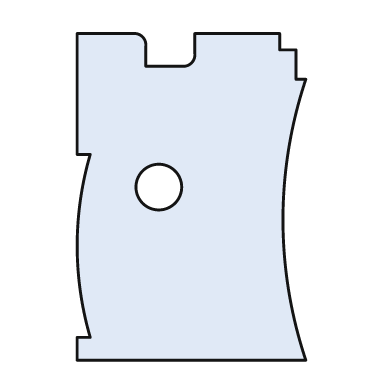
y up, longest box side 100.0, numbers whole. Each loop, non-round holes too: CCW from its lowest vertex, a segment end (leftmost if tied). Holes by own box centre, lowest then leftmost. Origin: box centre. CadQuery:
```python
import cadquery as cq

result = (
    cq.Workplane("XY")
    .moveTo(-35.0, -50.0)
    .lineTo(35.0, -50.0)
    .threePointArc((28.0, -7.0), (35.0, 36.0))
    .lineTo(32.0, 36.0)
    .lineTo(32.0, 45.0)
    .lineTo(27.0, 45.0)
    .lineTo(27.0, 50.0)
    .lineTo(1.0, 50.0)
    .lineTo(1.0, 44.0)
    .threePointArc((0.0, 41.0), (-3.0, 40.0))
    .lineTo(-14.0, 40.0)
    .lineTo(-14.0, 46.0)
    .threePointArc((-15.0, 49.0), (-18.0, 50.0))
    .lineTo(-35.0, 50.0)
    .lineTo(-35.0, 13.0)
    .lineTo(-31.0, 13.0)
    .threePointArc((-35.0, -15.0), (-31.0, -43.0))
    .lineTo(-35.0, -43.0)
    .close()
    .moveTo(-10.0, 3.0)
    .circle(7.0)
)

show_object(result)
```